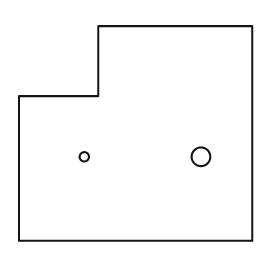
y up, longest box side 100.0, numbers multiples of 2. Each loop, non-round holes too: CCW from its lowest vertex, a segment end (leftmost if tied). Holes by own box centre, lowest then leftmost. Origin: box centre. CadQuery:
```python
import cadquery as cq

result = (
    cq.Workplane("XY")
    .moveTo(-50.0, -46.0)
    .lineTo(50.0, -46.0)
    .lineTo(50.0, 46.0)
    .lineTo(-16.0, 46.0)
    .lineTo(-16.0, 16.0)
    .lineTo(-50.0, 16.0)
    .close()
    .moveTo(-22.0, -10.0)
    .circle(2.0)
    .moveTo(28.0, -10.0)
    .circle(4.0)
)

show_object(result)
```